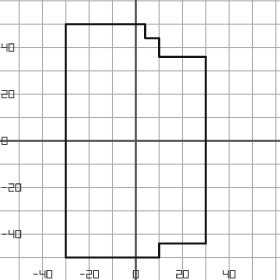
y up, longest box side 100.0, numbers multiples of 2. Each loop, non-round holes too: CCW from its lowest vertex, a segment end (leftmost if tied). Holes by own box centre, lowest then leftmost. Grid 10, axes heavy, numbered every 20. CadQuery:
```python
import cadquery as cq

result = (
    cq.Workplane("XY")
    .moveTo(-30.0, -50.0)
    .lineTo(10.0, -50.0)
    .lineTo(10.0, -44.0)
    .lineTo(30.0, -44.0)
    .lineTo(30.0, 36.0)
    .lineTo(10.0, 36.0)
    .lineTo(10.0, 44.0)
    .lineTo(4.0, 44.0)
    .lineTo(4.0, 50.0)
    .lineTo(-30.0, 50.0)
    .close()
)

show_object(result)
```